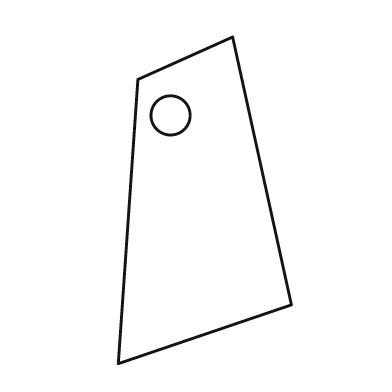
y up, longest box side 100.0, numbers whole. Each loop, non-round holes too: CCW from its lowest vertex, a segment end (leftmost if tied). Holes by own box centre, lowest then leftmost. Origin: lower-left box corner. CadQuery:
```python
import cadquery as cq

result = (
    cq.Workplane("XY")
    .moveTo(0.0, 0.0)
    .lineTo(53.0, 18.0)
    .lineTo(35.0, 100.0)
    .lineTo(6.0, 87.0)
    .close()
    .moveTo(16.0, 76.0)
    .circle(6.0)
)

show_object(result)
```